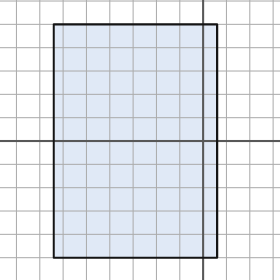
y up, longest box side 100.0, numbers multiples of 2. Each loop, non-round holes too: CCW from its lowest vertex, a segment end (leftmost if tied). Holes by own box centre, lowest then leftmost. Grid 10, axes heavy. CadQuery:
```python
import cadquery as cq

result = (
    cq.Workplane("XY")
    .moveTo(-64.0, -50.0)
    .lineTo(6.0, -50.0)
    .lineTo(6.0, 50.0)
    .lineTo(-64.0, 50.0)
    .close()
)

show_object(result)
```